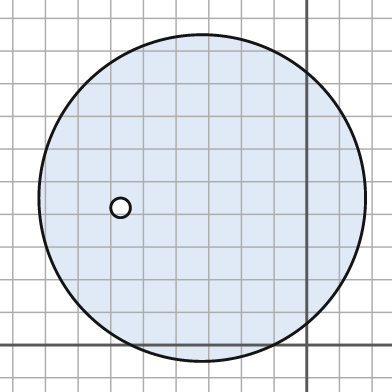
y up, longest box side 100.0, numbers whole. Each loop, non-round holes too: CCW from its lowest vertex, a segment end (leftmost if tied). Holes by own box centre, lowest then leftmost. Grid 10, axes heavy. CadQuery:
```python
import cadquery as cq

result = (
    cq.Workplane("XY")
    .moveTo(-32.0, 45.0)
    .circle(50.0)
    .moveTo(-57.0, 42.0)
    .circle(3.0)
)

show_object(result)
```